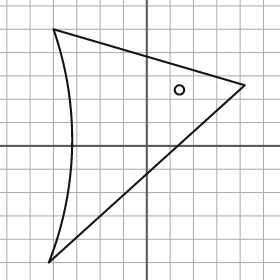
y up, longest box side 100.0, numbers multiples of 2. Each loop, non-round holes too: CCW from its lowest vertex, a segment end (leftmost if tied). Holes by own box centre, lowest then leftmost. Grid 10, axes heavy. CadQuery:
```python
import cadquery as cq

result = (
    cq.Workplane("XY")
    .moveTo(-42.0, -50.0)
    .lineTo(42.0, 26.0)
    .lineTo(-40.0, 50.0)
    .threePointArc((-32.0, 0.0), (-42.0, -50.0))
    .close()
    .moveTo(14.0, 24.0)
    .circle(2.0)
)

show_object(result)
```